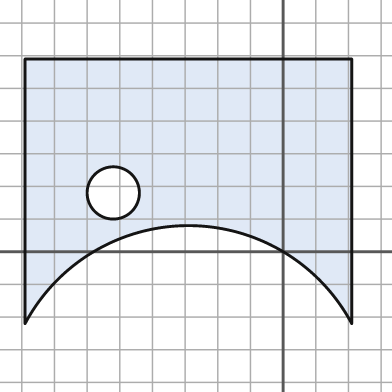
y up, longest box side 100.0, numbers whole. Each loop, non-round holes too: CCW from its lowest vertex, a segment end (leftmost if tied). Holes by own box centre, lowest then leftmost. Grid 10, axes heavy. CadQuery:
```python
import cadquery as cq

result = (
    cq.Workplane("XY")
    .moveTo(-79.0, -22.0)
    .threePointArc((-29.0, 8.0), (21.0, -22.0))
    .lineTo(21.0, 59.0)
    .lineTo(-79.0, 59.0)
    .close()
    .moveTo(-52.0, 18.0)
    .circle(8.0)
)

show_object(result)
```